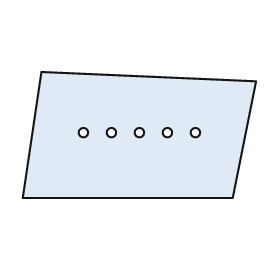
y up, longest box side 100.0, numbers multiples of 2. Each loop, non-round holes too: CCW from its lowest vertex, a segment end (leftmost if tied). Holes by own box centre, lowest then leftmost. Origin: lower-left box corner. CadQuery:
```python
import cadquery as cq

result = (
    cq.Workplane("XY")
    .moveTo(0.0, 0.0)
    .lineTo(90.0, 0.0)
    .lineTo(100.0, 50.0)
    .lineTo(8.0, 54.0)
    .close()
    .moveTo(26.0, 28.0)
    .circle(2.0)
    .moveTo(38.0, 28.0)
    .circle(2.0)
    .moveTo(50.0, 28.0)
    .circle(2.0)
    .moveTo(62.0, 28.0)
    .circle(2.0)
    .moveTo(74.0, 28.0)
    .circle(2.0)
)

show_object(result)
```